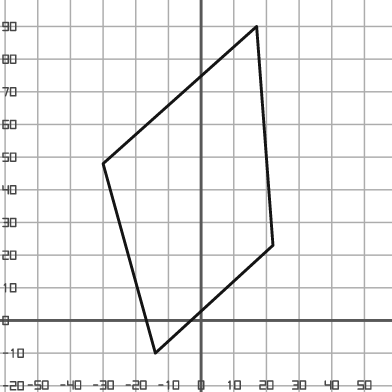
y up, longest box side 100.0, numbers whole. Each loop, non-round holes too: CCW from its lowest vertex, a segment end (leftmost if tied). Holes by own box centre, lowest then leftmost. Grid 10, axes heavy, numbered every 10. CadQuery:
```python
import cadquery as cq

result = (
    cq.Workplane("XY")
    .moveTo(-14.0, -10.0)
    .lineTo(22.0, 23.0)
    .lineTo(17.0, 90.0)
    .lineTo(-30.0, 48.0)
    .close()
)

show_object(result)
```